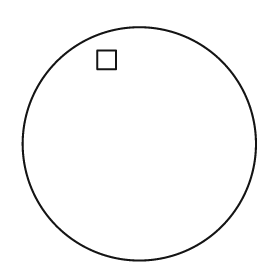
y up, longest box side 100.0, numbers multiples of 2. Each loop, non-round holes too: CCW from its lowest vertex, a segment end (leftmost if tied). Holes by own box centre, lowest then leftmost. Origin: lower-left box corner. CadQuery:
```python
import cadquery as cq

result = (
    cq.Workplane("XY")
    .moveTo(50.0, 50.0)
    .circle(50.0)
    .moveTo(32.0, 82.0)
    .lineTo(40.0, 82.0)
    .lineTo(40.0, 90.0)
    .lineTo(32.0, 90.0)
    .close()
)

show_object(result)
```